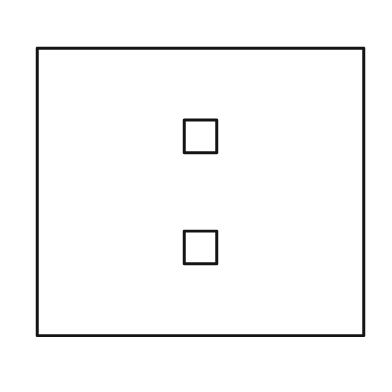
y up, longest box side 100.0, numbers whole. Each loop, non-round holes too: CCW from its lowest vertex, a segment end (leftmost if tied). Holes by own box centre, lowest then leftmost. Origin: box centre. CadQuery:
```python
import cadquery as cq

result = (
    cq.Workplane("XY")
    .moveTo(-50.0, -44.0)
    .lineTo(50.0, -44.0)
    .lineTo(50.0, 44.0)
    .lineTo(-50.0, 44.0)
    .close()
    .moveTo(-5.0, -22.0)
    .lineTo(5.0, -22.0)
    .lineTo(5.0, -12.0)
    .lineTo(-5.0, -12.0)
    .close()
    .moveTo(-5.0, 12.0)
    .lineTo(5.0, 12.0)
    .lineTo(5.0, 22.0)
    .lineTo(-5.0, 22.0)
    .close()
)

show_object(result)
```